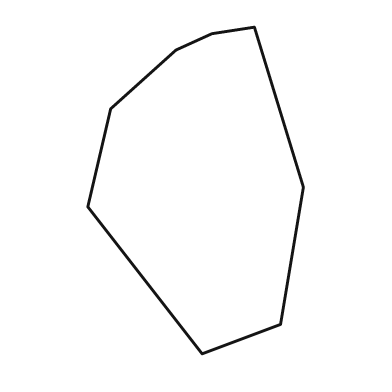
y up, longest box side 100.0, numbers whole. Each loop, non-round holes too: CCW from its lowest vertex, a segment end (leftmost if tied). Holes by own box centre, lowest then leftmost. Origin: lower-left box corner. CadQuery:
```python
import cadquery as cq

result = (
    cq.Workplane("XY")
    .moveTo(35.0, 0.0)
    .lineTo(59.0, 9.0)
    .lineTo(66.0, 51.0)
    .lineTo(51.0, 100.0)
    .lineTo(38.0, 98.0)
    .lineTo(27.0, 93.0)
    .lineTo(7.0, 75.0)
    .lineTo(0.0, 45.0)
    .close()
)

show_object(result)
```